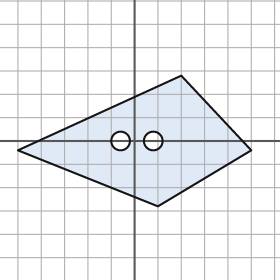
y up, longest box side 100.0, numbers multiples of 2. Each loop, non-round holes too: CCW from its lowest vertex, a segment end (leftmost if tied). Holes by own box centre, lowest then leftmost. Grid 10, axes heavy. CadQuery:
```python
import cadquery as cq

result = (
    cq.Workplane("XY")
    .moveTo(10.0, -28.0)
    .lineTo(50.0, -4.0)
    .lineTo(20.0, 28.0)
    .lineTo(-50.0, -4.0)
    .close()
    .moveTo(-6.0, 0.0)
    .circle(4.0)
    .moveTo(8.0, 0.0)
    .circle(4.0)
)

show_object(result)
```